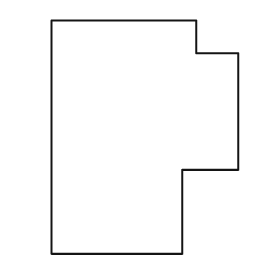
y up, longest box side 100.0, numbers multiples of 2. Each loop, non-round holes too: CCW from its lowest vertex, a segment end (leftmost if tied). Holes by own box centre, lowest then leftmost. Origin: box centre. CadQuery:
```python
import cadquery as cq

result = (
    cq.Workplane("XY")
    .moveTo(-40.0, -50.0)
    .lineTo(16.0, -50.0)
    .lineTo(16.0, -14.0)
    .lineTo(40.0, -14.0)
    .lineTo(40.0, 36.0)
    .lineTo(22.0, 36.0)
    .lineTo(22.0, 50.0)
    .lineTo(-40.0, 50.0)
    .close()
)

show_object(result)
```